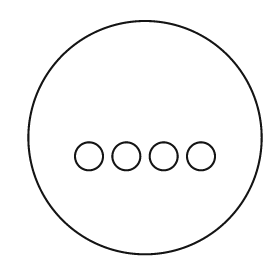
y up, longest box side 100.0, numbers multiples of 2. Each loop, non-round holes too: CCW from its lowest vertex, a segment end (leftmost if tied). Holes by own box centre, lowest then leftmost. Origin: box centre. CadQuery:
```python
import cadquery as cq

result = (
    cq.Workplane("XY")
    .moveTo(0.0, 0.0)
    .circle(50.0)
    .moveTo(-24.0, -8.0)
    .circle(6.0)
    .moveTo(-8.0, -8.0)
    .circle(6.0)
    .moveTo(8.0, -8.0)
    .circle(6.0)
    .moveTo(24.0, -8.0)
    .circle(6.0)
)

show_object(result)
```